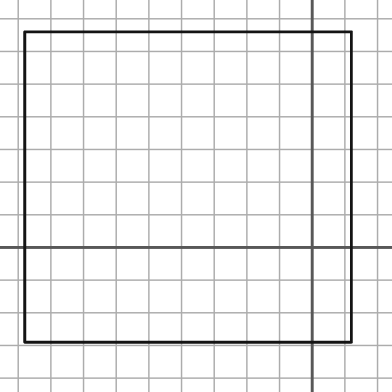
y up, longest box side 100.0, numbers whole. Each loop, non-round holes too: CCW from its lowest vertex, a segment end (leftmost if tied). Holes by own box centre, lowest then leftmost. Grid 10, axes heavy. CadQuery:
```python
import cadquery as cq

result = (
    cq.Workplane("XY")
    .moveTo(-88.0, -29.0)
    .lineTo(12.0, -29.0)
    .lineTo(12.0, 66.0)
    .lineTo(-88.0, 66.0)
    .close()
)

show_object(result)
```